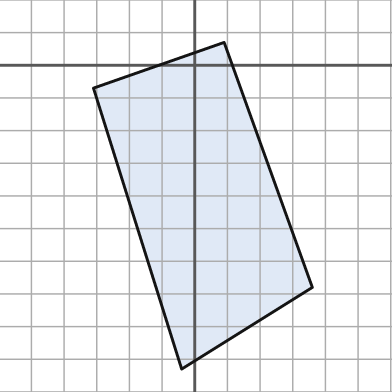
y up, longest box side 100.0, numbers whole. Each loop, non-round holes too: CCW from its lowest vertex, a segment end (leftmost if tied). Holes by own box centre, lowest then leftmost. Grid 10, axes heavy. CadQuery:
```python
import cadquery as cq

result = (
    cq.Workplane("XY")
    .moveTo(-4.0, -93.0)
    .lineTo(36.0, -68.0)
    .lineTo(9.0, 7.0)
    .lineTo(-31.0, -7.0)
    .close()
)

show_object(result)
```